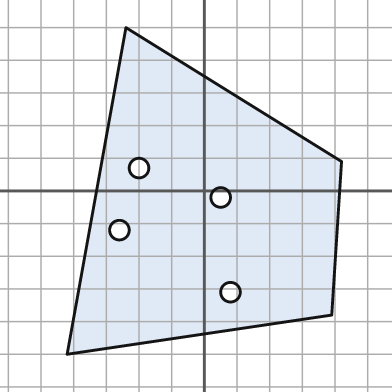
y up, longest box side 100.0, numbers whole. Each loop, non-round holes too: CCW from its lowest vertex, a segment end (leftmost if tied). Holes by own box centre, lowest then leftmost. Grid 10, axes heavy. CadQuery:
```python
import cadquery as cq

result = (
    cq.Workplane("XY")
    .moveTo(-42.0, -50.0)
    .lineTo(39.0, -38.0)
    .lineTo(42.0, 9.0)
    .lineTo(-24.0, 50.0)
    .close()
    .moveTo(8.0, -31.0)
    .circle(3.0)
    .moveTo(-26.0, -12.0)
    .circle(3.0)
    .moveTo(5.0, -2.0)
    .circle(3.0)
    .moveTo(-20.0, 7.0)
    .circle(3.0)
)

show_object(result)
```